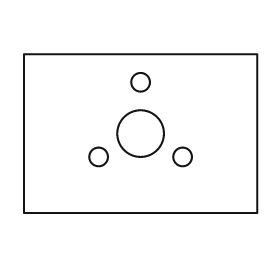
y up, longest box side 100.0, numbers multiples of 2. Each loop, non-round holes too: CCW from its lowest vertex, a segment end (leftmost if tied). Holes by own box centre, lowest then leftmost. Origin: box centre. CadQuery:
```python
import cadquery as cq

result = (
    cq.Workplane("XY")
    .moveTo(-50.0, -34.0)
    .lineTo(50.0, -34.0)
    .lineTo(50.0, 34.0)
    .lineTo(-50.0, 34.0)
    .close()
    .moveTo(-18.0, -10.0)
    .circle(4.0)
    .moveTo(18.0, -10.0)
    .circle(4.0)
    .moveTo(0.0, 0.0)
    .circle(10.0)
    .moveTo(0.0, 22.0)
    .circle(4.0)
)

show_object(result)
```